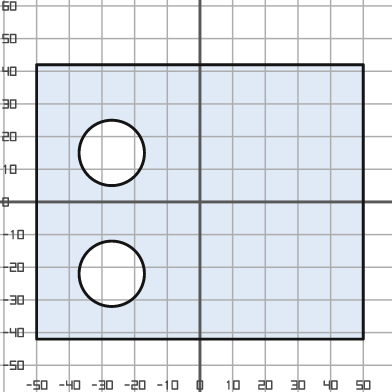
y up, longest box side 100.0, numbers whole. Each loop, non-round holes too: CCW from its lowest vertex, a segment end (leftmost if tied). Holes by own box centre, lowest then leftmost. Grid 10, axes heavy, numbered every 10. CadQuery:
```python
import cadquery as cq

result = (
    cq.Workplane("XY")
    .moveTo(-50.0, -42.0)
    .lineTo(50.0, -42.0)
    .lineTo(50.0, 42.0)
    .lineTo(-50.0, 42.0)
    .close()
    .moveTo(-27.0, -22.0)
    .circle(10.0)
    .moveTo(-27.0, 15.0)
    .circle(10.0)
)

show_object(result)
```